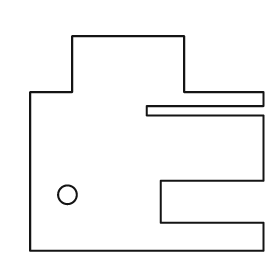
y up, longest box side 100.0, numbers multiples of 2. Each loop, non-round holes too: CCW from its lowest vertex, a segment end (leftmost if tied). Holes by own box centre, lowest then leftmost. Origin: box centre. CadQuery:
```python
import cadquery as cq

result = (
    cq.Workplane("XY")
    .moveTo(-50.0, -46.0)
    .lineTo(50.0, -46.0)
    .lineTo(50.0, -34.0)
    .lineTo(6.0, -34.0)
    .lineTo(6.0, -16.0)
    .lineTo(50.0, -16.0)
    .lineTo(50.0, 12.0)
    .lineTo(0.0, 12.0)
    .lineTo(0.0, 16.0)
    .lineTo(50.0, 16.0)
    .lineTo(50.0, 22.0)
    .lineTo(16.0, 22.0)
    .lineTo(16.0, 46.0)
    .lineTo(-32.0, 46.0)
    .lineTo(-32.0, 22.0)
    .lineTo(-50.0, 22.0)
    .close()
    .moveTo(-34.0, -22.0)
    .circle(4.0)
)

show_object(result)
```